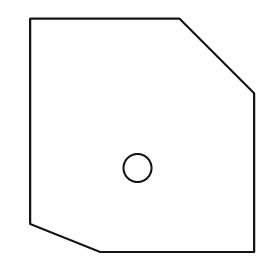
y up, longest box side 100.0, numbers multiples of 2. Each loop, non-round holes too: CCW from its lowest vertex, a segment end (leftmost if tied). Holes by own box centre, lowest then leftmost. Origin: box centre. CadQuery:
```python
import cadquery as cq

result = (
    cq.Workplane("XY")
    .moveTo(-18.0, -50.0)
    .lineTo(48.0, -50.0)
    .lineTo(48.0, 18.0)
    .lineTo(16.0, 50.0)
    .lineTo(-48.0, 50.0)
    .lineTo(-48.0, -38.0)
    .close()
    .moveTo(-2.0, -14.0)
    .circle(6.0)
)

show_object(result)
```